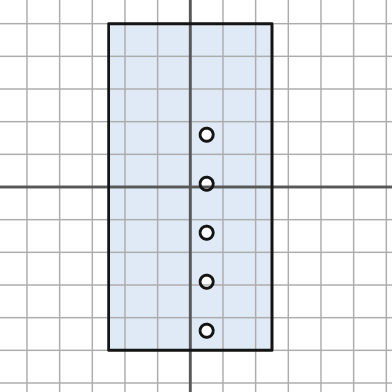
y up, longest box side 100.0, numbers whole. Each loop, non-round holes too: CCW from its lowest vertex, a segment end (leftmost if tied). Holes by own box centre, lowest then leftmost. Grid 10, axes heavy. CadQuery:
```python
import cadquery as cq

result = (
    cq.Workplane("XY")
    .moveTo(-25.0, -50.0)
    .lineTo(25.0, -50.0)
    .lineTo(25.0, 50.0)
    .lineTo(-25.0, 50.0)
    .close()
    .moveTo(5.0, -44.0)
    .circle(2.0)
    .moveTo(5.0, -29.0)
    .circle(2.0)
    .moveTo(5.0, -14.0)
    .circle(2.0)
    .moveTo(5.0, 1.0)
    .circle(2.0)
    .moveTo(5.0, 16.0)
    .circle(2.0)
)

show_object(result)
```